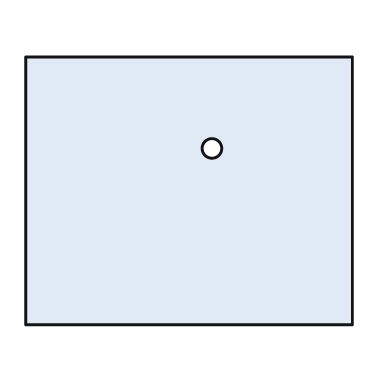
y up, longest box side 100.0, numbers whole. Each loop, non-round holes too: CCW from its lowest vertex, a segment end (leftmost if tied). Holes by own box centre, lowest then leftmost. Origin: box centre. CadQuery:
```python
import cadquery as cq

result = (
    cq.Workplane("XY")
    .moveTo(-50.0, -41.0)
    .lineTo(50.0, -41.0)
    .lineTo(50.0, 41.0)
    .lineTo(-50.0, 41.0)
    .close()
    .moveTo(7.0, 13.0)
    .circle(3.0)
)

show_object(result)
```